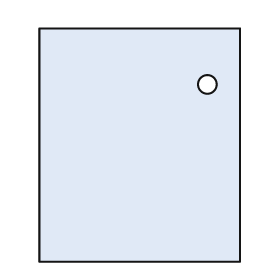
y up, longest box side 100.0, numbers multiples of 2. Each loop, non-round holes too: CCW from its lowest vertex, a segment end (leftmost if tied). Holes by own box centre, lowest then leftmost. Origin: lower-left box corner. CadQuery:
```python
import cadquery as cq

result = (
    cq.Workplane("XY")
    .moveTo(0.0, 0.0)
    .lineTo(86.0, 0.0)
    .lineTo(86.0, 100.0)
    .lineTo(0.0, 100.0)
    .close()
    .moveTo(72.0, 76.0)
    .circle(4.0)
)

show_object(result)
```